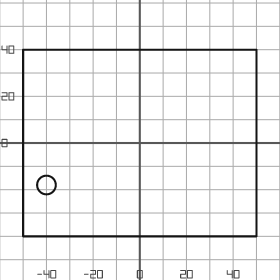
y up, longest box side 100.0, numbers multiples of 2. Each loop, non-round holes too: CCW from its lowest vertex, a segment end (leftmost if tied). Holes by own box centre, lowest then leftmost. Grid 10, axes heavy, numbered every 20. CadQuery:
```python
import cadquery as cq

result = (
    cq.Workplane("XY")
    .moveTo(-50.0, -40.0)
    .lineTo(50.0, -40.0)
    .lineTo(50.0, 40.0)
    .lineTo(-50.0, 40.0)
    .close()
    .moveTo(-40.0, -18.0)
    .circle(4.0)
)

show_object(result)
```